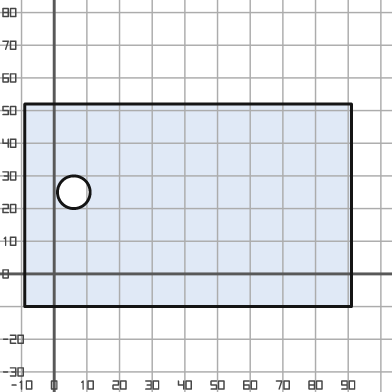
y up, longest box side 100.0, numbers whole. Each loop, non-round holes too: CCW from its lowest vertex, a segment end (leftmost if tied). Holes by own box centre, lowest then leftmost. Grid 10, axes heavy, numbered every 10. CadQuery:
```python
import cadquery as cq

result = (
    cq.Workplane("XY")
    .moveTo(-9.0, -10.0)
    .lineTo(91.0, -10.0)
    .lineTo(91.0, 52.0)
    .lineTo(-9.0, 52.0)
    .close()
    .moveTo(6.0, 25.0)
    .circle(5.0)
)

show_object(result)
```